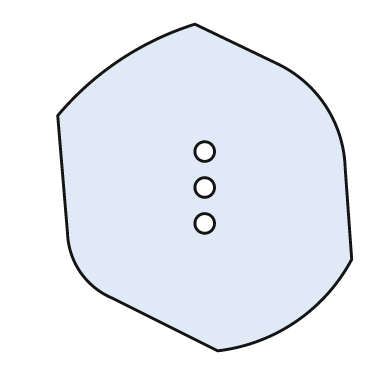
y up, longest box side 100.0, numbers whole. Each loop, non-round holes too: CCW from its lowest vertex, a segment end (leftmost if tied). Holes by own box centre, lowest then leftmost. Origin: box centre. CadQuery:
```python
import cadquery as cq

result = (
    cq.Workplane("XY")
    .moveTo(4.0, -50.0)
    .threePointArc((28.0, -41.0), (45.0, -22.0))
    .lineTo(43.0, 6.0)
    .threePointArc((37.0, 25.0), (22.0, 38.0))
    .lineTo(-3.0, 50.0)
    .threePointArc((-26.0, 39.0), (-45.0, 22.0))
    .lineTo(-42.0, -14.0)
    .threePointArc((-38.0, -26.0), (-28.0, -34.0))
    .close()
    .moveTo(0.0, -11.0)
    .circle(3.0)
    .moveTo(0.0, 0.0)
    .circle(3.0)
    .moveTo(0.0, 11.0)
    .circle(3.0)
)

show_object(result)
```